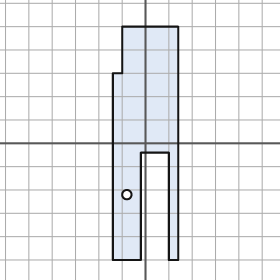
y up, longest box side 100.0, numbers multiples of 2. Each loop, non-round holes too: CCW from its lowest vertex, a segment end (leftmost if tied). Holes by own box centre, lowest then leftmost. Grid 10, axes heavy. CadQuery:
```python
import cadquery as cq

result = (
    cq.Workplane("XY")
    .moveTo(-14.0, -50.0)
    .lineTo(-2.0, -50.0)
    .lineTo(-2.0, -4.0)
    .lineTo(10.0, -4.0)
    .lineTo(10.0, -50.0)
    .lineTo(14.0, -50.0)
    .lineTo(14.0, 50.0)
    .lineTo(-10.0, 50.0)
    .lineTo(-10.0, 30.0)
    .lineTo(-14.0, 30.0)
    .close()
    .moveTo(-8.0, -22.0)
    .circle(2.0)
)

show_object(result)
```